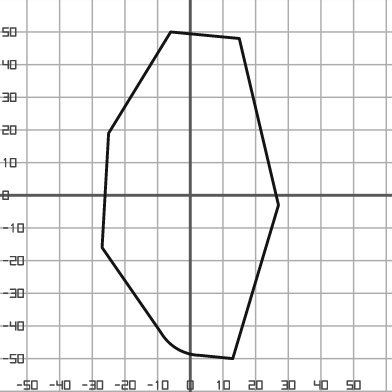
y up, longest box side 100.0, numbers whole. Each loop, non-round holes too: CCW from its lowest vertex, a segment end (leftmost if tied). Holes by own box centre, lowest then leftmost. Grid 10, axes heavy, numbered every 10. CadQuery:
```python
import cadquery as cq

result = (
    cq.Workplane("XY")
    .moveTo(13.0, -50.0)
    .lineTo(27.0, -3.0)
    .lineTo(15.0, 48.0)
    .lineTo(-6.0, 50.0)
    .lineTo(-25.0, 19.0)
    .lineTo(-27.0, -16.0)
    .lineTo(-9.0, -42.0)
    .threePointArc((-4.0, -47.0), (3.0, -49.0))
    .close()
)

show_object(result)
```